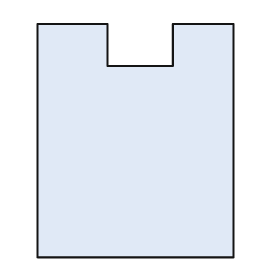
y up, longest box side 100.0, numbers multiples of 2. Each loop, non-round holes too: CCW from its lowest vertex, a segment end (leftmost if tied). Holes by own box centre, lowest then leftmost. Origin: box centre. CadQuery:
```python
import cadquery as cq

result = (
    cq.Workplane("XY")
    .moveTo(-42.0, -50.0)
    .lineTo(42.0, -50.0)
    .lineTo(42.0, 50.0)
    .lineTo(16.0, 50.0)
    .lineTo(16.0, 32.0)
    .lineTo(-12.0, 32.0)
    .lineTo(-12.0, 50.0)
    .lineTo(-42.0, 50.0)
    .close()
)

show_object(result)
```